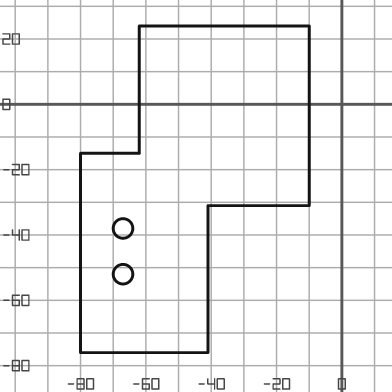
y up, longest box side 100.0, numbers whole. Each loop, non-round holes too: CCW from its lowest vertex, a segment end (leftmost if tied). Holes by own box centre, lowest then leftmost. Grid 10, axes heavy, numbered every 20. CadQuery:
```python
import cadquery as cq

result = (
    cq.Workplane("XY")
    .moveTo(-80.0, -76.0)
    .lineTo(-41.0, -76.0)
    .lineTo(-41.0, -31.0)
    .lineTo(-10.0, -31.0)
    .lineTo(-10.0, 24.0)
    .lineTo(-62.0, 24.0)
    .lineTo(-62.0, -15.0)
    .lineTo(-80.0, -15.0)
    .close()
    .moveTo(-67.0, -52.0)
    .circle(3.0)
    .moveTo(-67.0, -38.0)
    .circle(3.0)
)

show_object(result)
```